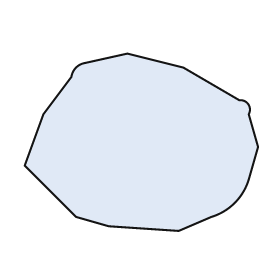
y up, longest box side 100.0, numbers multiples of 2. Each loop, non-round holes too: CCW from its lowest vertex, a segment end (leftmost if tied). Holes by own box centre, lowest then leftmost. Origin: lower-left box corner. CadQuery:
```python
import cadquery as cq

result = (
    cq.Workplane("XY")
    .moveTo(66.0, 0.0)
    .lineTo(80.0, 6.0)
    .threePointArc((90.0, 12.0), (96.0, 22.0))
    .lineTo(100.0, 36.0)
    .lineTo(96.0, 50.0)
    .threePointArc((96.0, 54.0), (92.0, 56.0))
    .lineTo(68.0, 70.0)
    .lineTo(44.0, 76.0)
    .lineTo(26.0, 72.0)
    .threePointArc((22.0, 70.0), (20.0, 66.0))
    .lineTo(8.0, 50.0)
    .lineTo(0.0, 28.0)
    .lineTo(22.0, 6.0)
    .lineTo(36.0, 2.0)
    .close()
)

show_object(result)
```